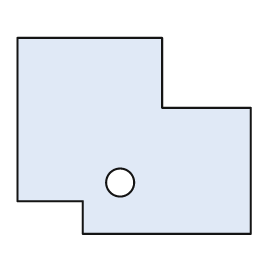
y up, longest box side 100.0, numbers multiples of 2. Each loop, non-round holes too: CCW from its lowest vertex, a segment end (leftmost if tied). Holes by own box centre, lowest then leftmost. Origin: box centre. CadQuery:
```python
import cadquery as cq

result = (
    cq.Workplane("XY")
    .moveTo(-22.0, -42.0)
    .lineTo(50.0, -42.0)
    .lineTo(50.0, 12.0)
    .lineTo(12.0, 12.0)
    .lineTo(12.0, 42.0)
    .lineTo(-50.0, 42.0)
    .lineTo(-50.0, -28.0)
    .lineTo(-22.0, -28.0)
    .close()
    .moveTo(-6.0, -20.0)
    .circle(6.0)
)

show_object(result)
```